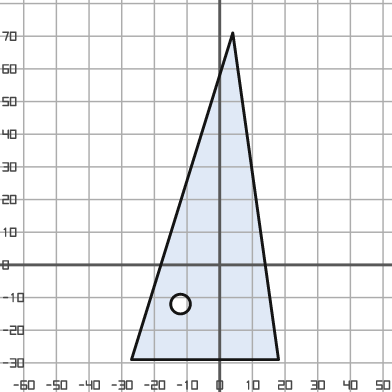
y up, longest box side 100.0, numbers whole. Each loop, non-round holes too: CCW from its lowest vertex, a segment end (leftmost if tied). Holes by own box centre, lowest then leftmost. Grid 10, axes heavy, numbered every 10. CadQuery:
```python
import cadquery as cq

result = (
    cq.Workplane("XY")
    .moveTo(-27.0, -29.0)
    .lineTo(18.0, -29.0)
    .lineTo(4.0, 71.0)
    .close()
    .moveTo(-12.0, -12.0)
    .circle(3.0)
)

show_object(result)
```